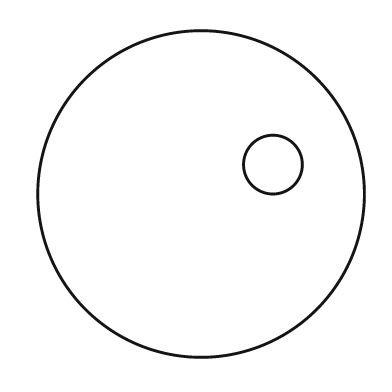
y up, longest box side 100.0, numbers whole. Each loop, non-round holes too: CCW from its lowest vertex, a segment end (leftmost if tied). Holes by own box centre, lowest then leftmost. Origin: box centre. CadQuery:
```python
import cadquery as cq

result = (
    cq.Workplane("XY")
    .moveTo(0.0, 0.0)
    .circle(50.0)
    .moveTo(22.0, 9.0)
    .circle(9.0)
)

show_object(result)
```